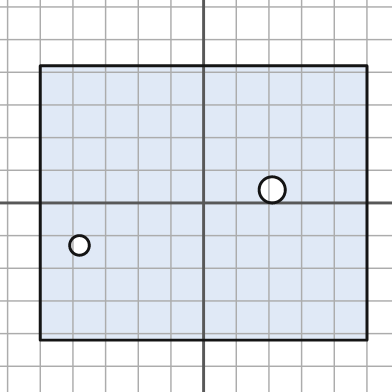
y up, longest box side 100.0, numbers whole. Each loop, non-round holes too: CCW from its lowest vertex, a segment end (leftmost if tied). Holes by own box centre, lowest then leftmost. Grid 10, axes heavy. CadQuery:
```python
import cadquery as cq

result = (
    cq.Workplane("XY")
    .moveTo(-50.0, -42.0)
    .lineTo(50.0, -42.0)
    .lineTo(50.0, 42.0)
    .lineTo(-50.0, 42.0)
    .close()
    .moveTo(-38.0, -13.0)
    .circle(3.0)
    .moveTo(21.0, 4.0)
    .circle(4.0)
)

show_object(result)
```